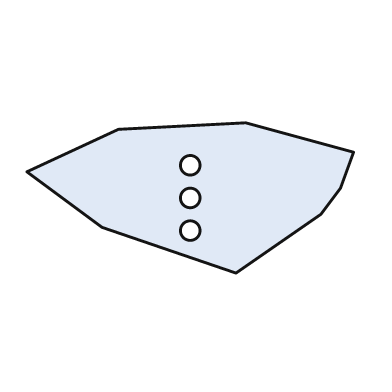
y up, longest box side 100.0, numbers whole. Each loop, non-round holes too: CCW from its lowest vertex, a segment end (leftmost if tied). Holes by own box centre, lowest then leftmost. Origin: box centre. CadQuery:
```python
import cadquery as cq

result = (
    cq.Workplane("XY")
    .moveTo(14.0, -23.0)
    .lineTo(40.0, -5.0)
    .lineTo(46.0, 3.0)
    .lineTo(50.0, 14.0)
    .lineTo(17.0, 23.0)
    .lineTo(-22.0, 21.0)
    .lineTo(-50.0, 8.0)
    .lineTo(-27.0, -9.0)
    .close()
    .moveTo(0.0, -10.0)
    .circle(3.0)
    .moveTo(0.0, 0.0)
    .circle(3.0)
    .moveTo(0.0, 10.0)
    .circle(3.0)
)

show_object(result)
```